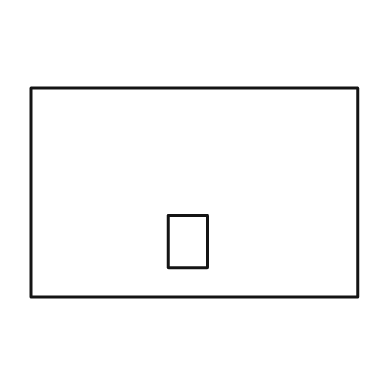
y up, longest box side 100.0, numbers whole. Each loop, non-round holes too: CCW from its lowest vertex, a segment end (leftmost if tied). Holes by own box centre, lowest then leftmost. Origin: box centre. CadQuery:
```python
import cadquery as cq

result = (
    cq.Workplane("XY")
    .moveTo(-50.0, -32.0)
    .lineTo(50.0, -32.0)
    .lineTo(50.0, 32.0)
    .lineTo(-50.0, 32.0)
    .close()
    .moveTo(-8.0, -23.0)
    .lineTo(4.0, -23.0)
    .lineTo(4.0, -7.0)
    .lineTo(-8.0, -7.0)
    .close()
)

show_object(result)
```